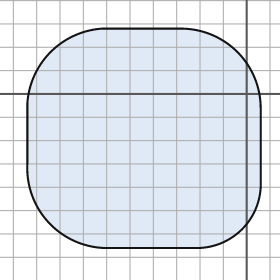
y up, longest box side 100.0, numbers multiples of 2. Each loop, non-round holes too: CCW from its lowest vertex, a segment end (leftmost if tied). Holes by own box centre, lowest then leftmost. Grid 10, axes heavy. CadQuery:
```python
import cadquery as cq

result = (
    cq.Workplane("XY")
    .moveTo(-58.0, -66.0)
    .lineTo(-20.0, -66.0)
    .threePointArc((-2.0, -58.0), (6.0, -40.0))
    .lineTo(6.0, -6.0)
    .threePointArc((-4.0, 18.0), (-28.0, 28.0))
    .lineTo(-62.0, 28.0)
    .threePointArc((-84.0, 18.0), (-94.0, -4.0))
    .lineTo(-94.0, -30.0)
    .threePointArc((-84.0, -56.0), (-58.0, -66.0))
    .close()
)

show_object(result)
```